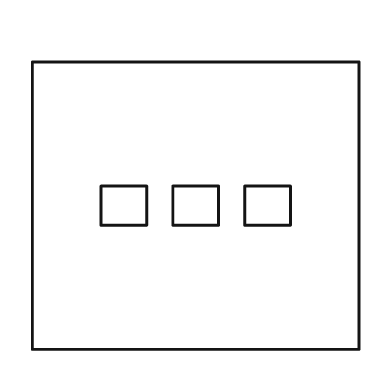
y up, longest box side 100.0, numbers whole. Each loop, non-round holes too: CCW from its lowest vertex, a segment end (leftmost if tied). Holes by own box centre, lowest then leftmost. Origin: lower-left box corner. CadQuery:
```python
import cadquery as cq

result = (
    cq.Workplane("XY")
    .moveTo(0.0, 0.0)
    .lineTo(100.0, 0.0)
    .lineTo(100.0, 88.0)
    .lineTo(0.0, 88.0)
    .close()
    .moveTo(21.0, 38.0)
    .lineTo(35.0, 38.0)
    .lineTo(35.0, 50.0)
    .lineTo(21.0, 50.0)
    .close()
    .moveTo(43.0, 38.0)
    .lineTo(57.0, 38.0)
    .lineTo(57.0, 50.0)
    .lineTo(43.0, 50.0)
    .close()
    .moveTo(65.0, 38.0)
    .lineTo(79.0, 38.0)
    .lineTo(79.0, 50.0)
    .lineTo(65.0, 50.0)
    .close()
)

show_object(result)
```